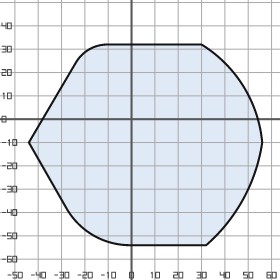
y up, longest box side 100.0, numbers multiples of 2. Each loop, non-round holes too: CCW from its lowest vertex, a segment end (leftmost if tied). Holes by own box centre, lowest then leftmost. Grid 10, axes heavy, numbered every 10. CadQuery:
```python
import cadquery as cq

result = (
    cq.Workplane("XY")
    .moveTo(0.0, -54.0)
    .lineTo(32.0, -54.0)
    .threePointArc((48.0, -34.0), (56.0, -10.0))
    .threePointArc((48.0, 14.0), (30.0, 32.0))
    .lineTo(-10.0, 32.0)
    .threePointArc((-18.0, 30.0), (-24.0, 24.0))
    .lineTo(-44.0, -10.0)
    .lineTo(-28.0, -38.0)
    .threePointArc((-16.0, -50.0), (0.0, -54.0))
    .close()
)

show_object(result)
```